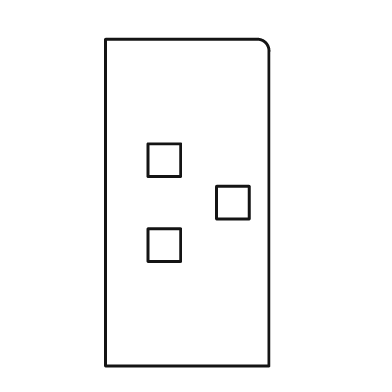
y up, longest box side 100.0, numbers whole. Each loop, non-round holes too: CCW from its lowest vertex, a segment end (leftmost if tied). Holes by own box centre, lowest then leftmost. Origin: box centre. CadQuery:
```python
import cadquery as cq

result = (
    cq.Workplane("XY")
    .moveTo(-25.0, -50.0)
    .lineTo(25.0, -50.0)
    .lineTo(25.0, 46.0)
    .threePointArc((24.0, 49.0), (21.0, 50.0))
    .lineTo(-25.0, 50.0)
    .close()
    .moveTo(-12.0, -18.0)
    .lineTo(-2.0, -18.0)
    .lineTo(-2.0, -8.0)
    .lineTo(-12.0, -8.0)
    .close()
    .moveTo(9.0, -5.0)
    .lineTo(19.0, -5.0)
    .lineTo(19.0, 5.0)
    .lineTo(9.0, 5.0)
    .close()
    .moveTo(-12.0, 8.0)
    .lineTo(-2.0, 8.0)
    .lineTo(-2.0, 18.0)
    .lineTo(-12.0, 18.0)
    .close()
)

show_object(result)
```